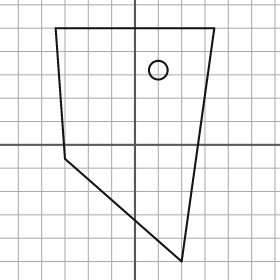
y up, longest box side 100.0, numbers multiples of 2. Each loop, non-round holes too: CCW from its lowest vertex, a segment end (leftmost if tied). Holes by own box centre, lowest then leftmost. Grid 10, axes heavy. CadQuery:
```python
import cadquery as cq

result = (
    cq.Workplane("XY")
    .moveTo(20.0, -50.0)
    .lineTo(34.0, 50.0)
    .lineTo(-34.0, 50.0)
    .lineTo(-30.0, -6.0)
    .close()
    .moveTo(10.0, 32.0)
    .circle(4.0)
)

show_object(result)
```